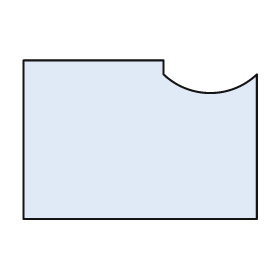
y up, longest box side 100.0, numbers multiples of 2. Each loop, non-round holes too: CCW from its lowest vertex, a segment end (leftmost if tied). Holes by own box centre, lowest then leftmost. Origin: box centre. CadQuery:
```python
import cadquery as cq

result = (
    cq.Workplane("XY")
    .moveTo(-50.0, -34.0)
    .lineTo(50.0, -34.0)
    .lineTo(50.0, 28.0)
    .threePointArc((30.0, 20.0), (10.0, 28.0))
    .lineTo(10.0, 34.0)
    .lineTo(-50.0, 34.0)
    .close()
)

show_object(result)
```